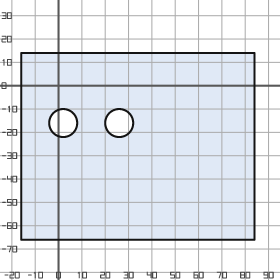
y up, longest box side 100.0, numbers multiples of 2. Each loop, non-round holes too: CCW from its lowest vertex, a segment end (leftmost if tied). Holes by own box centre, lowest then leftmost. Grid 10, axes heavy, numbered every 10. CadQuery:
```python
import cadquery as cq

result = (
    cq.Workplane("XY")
    .moveTo(-16.0, -66.0)
    .lineTo(84.0, -66.0)
    .lineTo(84.0, 14.0)
    .lineTo(-16.0, 14.0)
    .close()
    .moveTo(2.0, -16.0)
    .circle(6.0)
    .moveTo(26.0, -16.0)
    .circle(6.0)
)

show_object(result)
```